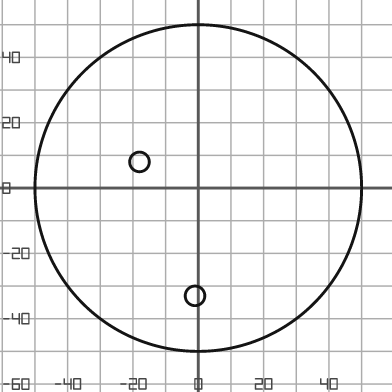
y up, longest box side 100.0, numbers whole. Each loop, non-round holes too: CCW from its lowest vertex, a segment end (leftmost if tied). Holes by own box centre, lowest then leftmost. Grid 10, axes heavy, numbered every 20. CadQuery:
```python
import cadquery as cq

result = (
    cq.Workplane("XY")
    .moveTo(0.0, 0.0)
    .circle(50.0)
    .moveTo(-1.0, -33.0)
    .circle(3.0)
    .moveTo(-18.0, 8.0)
    .circle(3.0)
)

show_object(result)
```